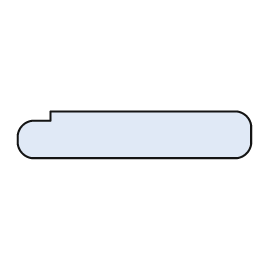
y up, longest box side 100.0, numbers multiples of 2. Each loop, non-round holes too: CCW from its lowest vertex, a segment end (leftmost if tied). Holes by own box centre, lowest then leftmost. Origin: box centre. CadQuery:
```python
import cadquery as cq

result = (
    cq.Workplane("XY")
    .moveTo(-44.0, -10.0)
    .lineTo(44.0, -10.0)
    .threePointArc((48.0, -8.0), (50.0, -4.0))
    .lineTo(50.0, 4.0)
    .threePointArc((48.0, 8.0), (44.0, 10.0))
    .lineTo(-36.0, 10.0)
    .lineTo(-36.0, 6.0)
    .lineTo(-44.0, 6.0)
    .threePointArc((-48.0, 4.0), (-50.0, 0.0))
    .lineTo(-50.0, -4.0)
    .threePointArc((-48.0, -8.0), (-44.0, -10.0))
    .close()
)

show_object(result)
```